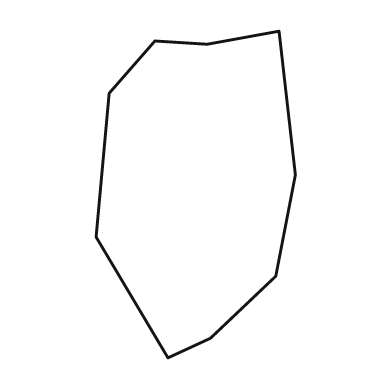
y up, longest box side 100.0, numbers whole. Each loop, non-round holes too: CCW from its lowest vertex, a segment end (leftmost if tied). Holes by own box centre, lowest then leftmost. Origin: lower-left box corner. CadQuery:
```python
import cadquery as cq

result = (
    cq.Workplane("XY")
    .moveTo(22.0, 0.0)
    .lineTo(35.0, 6.0)
    .lineTo(55.0, 25.0)
    .lineTo(61.0, 56.0)
    .lineTo(56.0, 100.0)
    .lineTo(34.0, 96.0)
    .lineTo(18.0, 97.0)
    .lineTo(4.0, 81.0)
    .lineTo(0.0, 37.0)
    .close()
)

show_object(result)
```